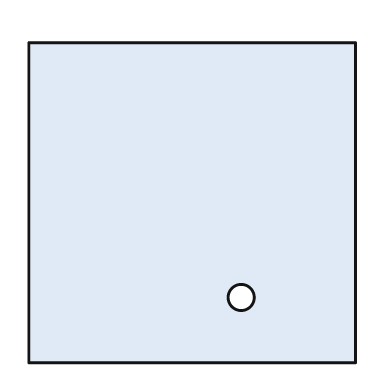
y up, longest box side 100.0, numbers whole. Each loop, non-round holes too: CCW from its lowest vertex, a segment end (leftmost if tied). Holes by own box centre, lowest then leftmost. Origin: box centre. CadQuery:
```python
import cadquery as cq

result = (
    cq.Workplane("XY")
    .moveTo(-50.0, -49.0)
    .lineTo(50.0, -49.0)
    .lineTo(50.0, 49.0)
    .lineTo(-50.0, 49.0)
    .close()
    .moveTo(15.0, -29.0)
    .circle(4.0)
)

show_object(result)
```